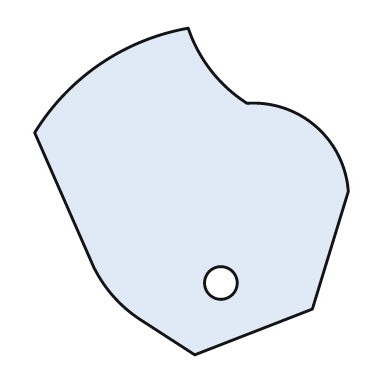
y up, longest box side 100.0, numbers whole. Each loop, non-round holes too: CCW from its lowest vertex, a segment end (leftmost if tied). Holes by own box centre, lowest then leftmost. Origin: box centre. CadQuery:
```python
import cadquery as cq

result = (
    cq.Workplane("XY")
    .moveTo(1.0, -50.0)
    .lineTo(37.0, -36.0)
    .lineTo(48.0, 0.0)
    .threePointArc((38.0, 20.0), (17.0, 27.0))
    .threePointArc((6.0, 37.0), (-1.0, 50.0))
    .threePointArc((-28.0, 39.0), (-48.0, 18.0))
    .lineTo(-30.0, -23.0)
    .threePointArc((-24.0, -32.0), (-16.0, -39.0))
    .close()
    .moveTo(9.0, -28.0)
    .circle(5.0)
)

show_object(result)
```